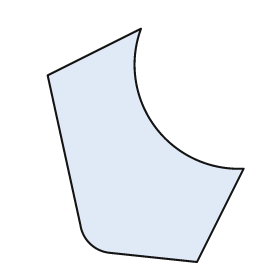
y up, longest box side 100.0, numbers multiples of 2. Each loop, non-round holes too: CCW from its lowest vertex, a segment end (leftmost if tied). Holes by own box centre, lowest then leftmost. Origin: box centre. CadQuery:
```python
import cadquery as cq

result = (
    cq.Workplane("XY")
    .moveTo(22.0, -50.0)
    .lineTo(42.0, -10.0)
    .threePointArc((4.0, 8.0), (-2.0, 50.0))
    .lineTo(-42.0, 30.0)
    .lineTo(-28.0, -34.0)
    .threePointArc((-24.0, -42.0), (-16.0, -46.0))
    .close()
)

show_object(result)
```